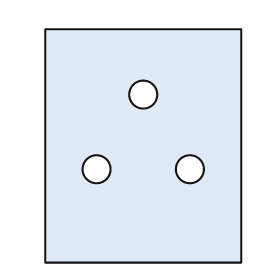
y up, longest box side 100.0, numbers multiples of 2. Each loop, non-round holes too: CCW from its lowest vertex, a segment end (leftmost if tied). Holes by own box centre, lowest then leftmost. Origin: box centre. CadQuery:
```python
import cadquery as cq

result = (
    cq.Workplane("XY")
    .moveTo(-42.0, -50.0)
    .lineTo(42.0, -50.0)
    .lineTo(42.0, 50.0)
    .lineTo(-42.0, 50.0)
    .close()
    .moveTo(-20.0, -10.0)
    .circle(6.0)
    .moveTo(20.0, -10.0)
    .circle(6.0)
    .moveTo(0.0, 22.0)
    .circle(6.0)
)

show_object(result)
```